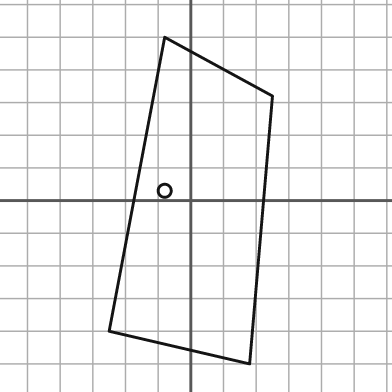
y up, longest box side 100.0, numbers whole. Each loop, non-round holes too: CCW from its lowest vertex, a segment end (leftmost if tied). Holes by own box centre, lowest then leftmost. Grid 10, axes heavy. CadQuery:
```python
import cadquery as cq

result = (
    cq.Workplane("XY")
    .moveTo(18.0, -50.0)
    .lineTo(25.0, 32.0)
    .lineTo(-8.0, 50.0)
    .lineTo(-25.0, -40.0)
    .close()
    .moveTo(-8.0, 3.0)
    .circle(2.0)
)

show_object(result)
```